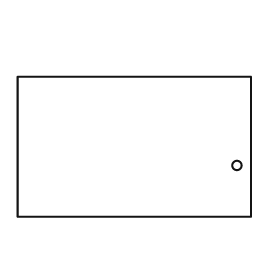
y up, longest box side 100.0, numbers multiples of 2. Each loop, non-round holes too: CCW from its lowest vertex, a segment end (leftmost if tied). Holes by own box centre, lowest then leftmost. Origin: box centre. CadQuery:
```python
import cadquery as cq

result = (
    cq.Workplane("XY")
    .moveTo(-50.0, -30.0)
    .lineTo(50.0, -30.0)
    .lineTo(50.0, 30.0)
    .lineTo(-50.0, 30.0)
    .close()
    .moveTo(44.0, -8.0)
    .circle(2.0)
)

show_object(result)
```